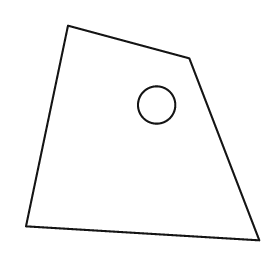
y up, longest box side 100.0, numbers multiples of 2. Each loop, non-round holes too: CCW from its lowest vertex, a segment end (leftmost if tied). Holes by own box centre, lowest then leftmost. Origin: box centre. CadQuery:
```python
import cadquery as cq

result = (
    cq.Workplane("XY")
    .moveTo(50.0, -46.0)
    .lineTo(20.0, 32.0)
    .lineTo(-32.0, 46.0)
    .lineTo(-50.0, -40.0)
    .close()
    .moveTo(6.0, 12.0)
    .circle(8.0)
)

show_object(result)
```